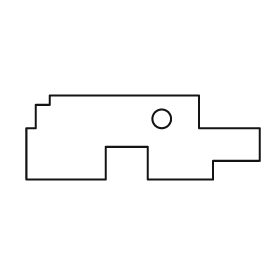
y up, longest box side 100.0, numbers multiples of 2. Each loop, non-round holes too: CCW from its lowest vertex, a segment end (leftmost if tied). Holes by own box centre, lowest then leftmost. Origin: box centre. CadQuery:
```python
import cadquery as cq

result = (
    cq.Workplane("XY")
    .moveTo(-50.0, -18.0)
    .lineTo(-16.0, -18.0)
    .lineTo(-16.0, -4.0)
    .lineTo(2.0, -4.0)
    .lineTo(2.0, -18.0)
    .lineTo(30.0, -18.0)
    .lineTo(30.0, -10.0)
    .lineTo(50.0, -10.0)
    .lineTo(50.0, 4.0)
    .lineTo(24.0, 4.0)
    .lineTo(24.0, 18.0)
    .lineTo(-40.0, 18.0)
    .lineTo(-40.0, 14.0)
    .lineTo(-46.0, 14.0)
    .lineTo(-46.0, 4.0)
    .lineTo(-50.0, 4.0)
    .close()
    .moveTo(8.0, 8.0)
    .circle(4.0)
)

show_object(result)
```